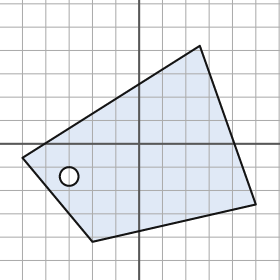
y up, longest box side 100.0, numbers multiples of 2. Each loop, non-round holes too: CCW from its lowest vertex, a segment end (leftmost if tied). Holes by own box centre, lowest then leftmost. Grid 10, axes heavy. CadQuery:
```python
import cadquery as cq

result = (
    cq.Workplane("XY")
    .moveTo(-20.0, -42.0)
    .lineTo(50.0, -26.0)
    .lineTo(26.0, 42.0)
    .lineTo(-50.0, -6.0)
    .close()
    .moveTo(-30.0, -14.0)
    .circle(4.0)
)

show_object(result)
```